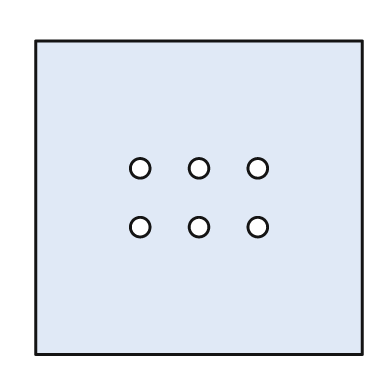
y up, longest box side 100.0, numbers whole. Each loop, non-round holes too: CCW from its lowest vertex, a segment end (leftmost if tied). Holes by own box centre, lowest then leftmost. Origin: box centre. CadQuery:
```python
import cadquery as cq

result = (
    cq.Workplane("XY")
    .moveTo(-50.0, -48.0)
    .lineTo(50.0, -48.0)
    .lineTo(50.0, 48.0)
    .lineTo(-50.0, 48.0)
    .close()
    .moveTo(-18.0, -9.0)
    .circle(3.0)
    .moveTo(0.0, -9.0)
    .circle(3.0)
    .moveTo(18.0, -9.0)
    .circle(3.0)
    .moveTo(-18.0, 9.0)
    .circle(3.0)
    .moveTo(0.0, 9.0)
    .circle(3.0)
    .moveTo(18.0, 9.0)
    .circle(3.0)
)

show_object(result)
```